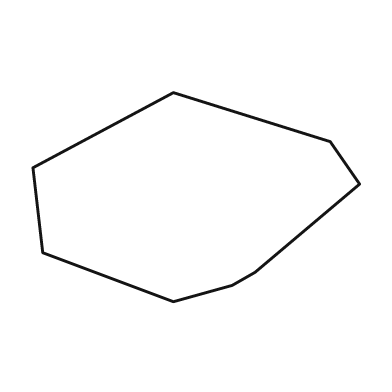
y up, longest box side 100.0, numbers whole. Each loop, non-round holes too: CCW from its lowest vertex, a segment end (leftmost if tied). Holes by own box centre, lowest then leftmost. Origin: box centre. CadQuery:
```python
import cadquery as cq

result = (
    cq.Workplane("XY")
    .moveTo(-7.0, -32.0)
    .lineTo(11.0, -27.0)
    .lineTo(18.0, -23.0)
    .lineTo(50.0, 4.0)
    .lineTo(41.0, 17.0)
    .lineTo(-7.0, 32.0)
    .lineTo(-50.0, 9.0)
    .lineTo(-47.0, -17.0)
    .close()
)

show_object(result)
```